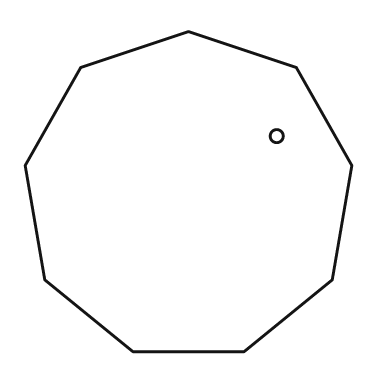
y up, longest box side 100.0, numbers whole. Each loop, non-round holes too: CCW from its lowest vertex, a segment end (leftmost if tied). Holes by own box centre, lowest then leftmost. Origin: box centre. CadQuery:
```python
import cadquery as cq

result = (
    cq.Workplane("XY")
    .moveTo(-17.0, -49.0)
    .lineTo(17.0, -49.0)
    .lineTo(44.0, -27.0)
    .lineTo(50.0, 8.0)
    .lineTo(33.0, 38.0)
    .lineTo(0.0, 49.0)
    .lineTo(-33.0, 38.0)
    .lineTo(-50.0, 8.0)
    .lineTo(-44.0, -27.0)
    .close()
    .moveTo(27.0, 17.0)
    .circle(2.0)
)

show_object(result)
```